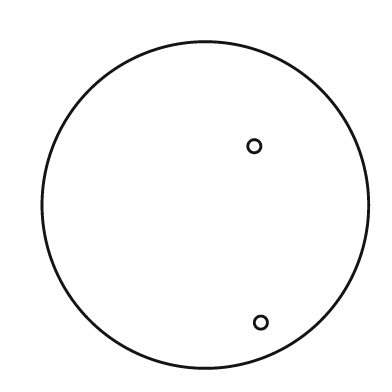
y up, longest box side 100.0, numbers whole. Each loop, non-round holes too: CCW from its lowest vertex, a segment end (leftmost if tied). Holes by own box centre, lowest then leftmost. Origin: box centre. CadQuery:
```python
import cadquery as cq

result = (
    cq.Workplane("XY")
    .moveTo(0.0, 0.0)
    .circle(50.0)
    .moveTo(17.0, -36.0)
    .circle(2.0)
    .moveTo(15.0, 18.0)
    .circle(2.0)
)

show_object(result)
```